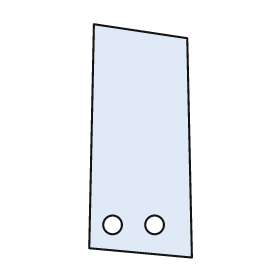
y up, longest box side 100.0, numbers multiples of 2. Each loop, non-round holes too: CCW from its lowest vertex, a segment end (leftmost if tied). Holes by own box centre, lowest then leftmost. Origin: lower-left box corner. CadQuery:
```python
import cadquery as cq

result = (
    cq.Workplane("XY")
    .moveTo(44.0, 0.0)
    .lineTo(42.0, 94.0)
    .lineTo(2.0, 100.0)
    .lineTo(0.0, 4.0)
    .close()
    .moveTo(10.0, 14.0)
    .circle(4.0)
    .moveTo(28.0, 14.0)
    .circle(4.0)
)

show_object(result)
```